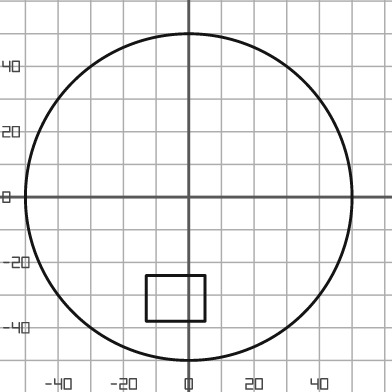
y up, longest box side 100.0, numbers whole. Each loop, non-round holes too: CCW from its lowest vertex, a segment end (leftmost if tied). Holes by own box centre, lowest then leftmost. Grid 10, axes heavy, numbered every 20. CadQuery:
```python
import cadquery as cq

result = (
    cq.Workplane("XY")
    .moveTo(0.0, 0.0)
    .circle(50.0)
    .moveTo(-13.0, -38.0)
    .lineTo(5.0, -38.0)
    .lineTo(5.0, -24.0)
    .lineTo(-13.0, -24.0)
    .close()
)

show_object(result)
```